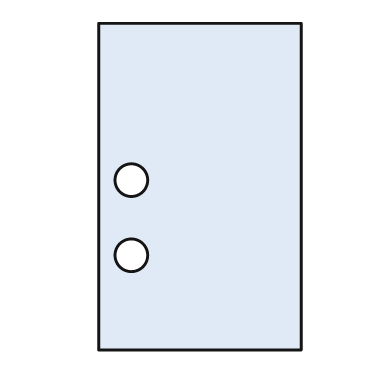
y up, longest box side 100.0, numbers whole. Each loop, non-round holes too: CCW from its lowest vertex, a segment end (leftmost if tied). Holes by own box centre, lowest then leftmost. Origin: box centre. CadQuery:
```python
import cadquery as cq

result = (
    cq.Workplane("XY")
    .moveTo(-31.0, -50.0)
    .lineTo(31.0, -50.0)
    .lineTo(31.0, 50.0)
    .lineTo(-31.0, 50.0)
    .close()
    .moveTo(-21.0, -21.0)
    .circle(5.0)
    .moveTo(-21.0, 2.0)
    .circle(5.0)
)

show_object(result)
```